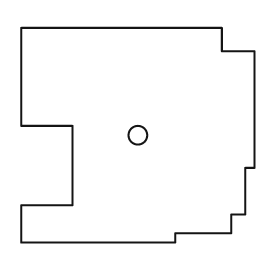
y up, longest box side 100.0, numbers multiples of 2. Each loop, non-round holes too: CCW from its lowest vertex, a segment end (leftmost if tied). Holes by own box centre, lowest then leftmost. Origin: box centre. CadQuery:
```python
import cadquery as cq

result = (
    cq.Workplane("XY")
    .moveTo(-50.0, -46.0)
    .lineTo(16.0, -46.0)
    .lineTo(16.0, -42.0)
    .lineTo(40.0, -42.0)
    .lineTo(40.0, -34.0)
    .lineTo(46.0, -34.0)
    .lineTo(46.0, -14.0)
    .lineTo(50.0, -14.0)
    .lineTo(50.0, 36.0)
    .lineTo(36.0, 36.0)
    .lineTo(36.0, 46.0)
    .lineTo(-50.0, 46.0)
    .lineTo(-50.0, 4.0)
    .lineTo(-28.0, 4.0)
    .lineTo(-28.0, -30.0)
    .lineTo(-50.0, -30.0)
    .close()
    .moveTo(0.0, 0.0)
    .circle(4.0)
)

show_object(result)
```